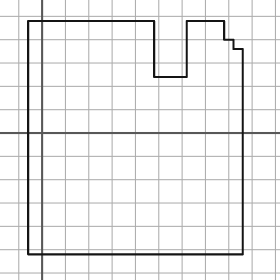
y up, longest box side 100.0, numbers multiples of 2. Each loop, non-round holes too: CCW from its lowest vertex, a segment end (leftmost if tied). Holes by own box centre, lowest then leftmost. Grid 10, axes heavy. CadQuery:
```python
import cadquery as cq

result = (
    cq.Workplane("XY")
    .moveTo(-6.0, -52.0)
    .lineTo(86.0, -52.0)
    .lineTo(86.0, 36.0)
    .lineTo(82.0, 36.0)
    .lineTo(82.0, 40.0)
    .lineTo(78.0, 40.0)
    .lineTo(78.0, 48.0)
    .lineTo(62.0, 48.0)
    .lineTo(62.0, 24.0)
    .lineTo(48.0, 24.0)
    .lineTo(48.0, 48.0)
    .lineTo(-6.0, 48.0)
    .close()
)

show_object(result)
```